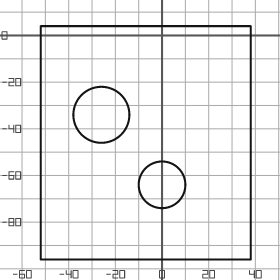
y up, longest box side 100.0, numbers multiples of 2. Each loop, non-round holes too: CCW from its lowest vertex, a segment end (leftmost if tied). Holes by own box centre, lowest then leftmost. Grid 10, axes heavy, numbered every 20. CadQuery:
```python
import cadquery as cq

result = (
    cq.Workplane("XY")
    .moveTo(-52.0, -96.0)
    .lineTo(38.0, -96.0)
    .lineTo(38.0, 4.0)
    .lineTo(-52.0, 4.0)
    .close()
    .moveTo(0.0, -64.0)
    .circle(10.0)
    .moveTo(-26.0, -34.0)
    .circle(12.0)
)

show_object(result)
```